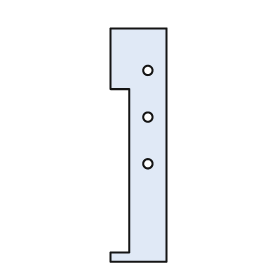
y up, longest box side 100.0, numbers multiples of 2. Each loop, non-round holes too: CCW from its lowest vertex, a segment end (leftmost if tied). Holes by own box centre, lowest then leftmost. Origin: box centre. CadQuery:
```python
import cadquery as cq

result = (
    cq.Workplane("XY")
    .moveTo(-12.0, -50.0)
    .lineTo(12.0, -50.0)
    .lineTo(12.0, 50.0)
    .lineTo(-12.0, 50.0)
    .lineTo(-12.0, 24.0)
    .lineTo(-4.0, 24.0)
    .lineTo(-4.0, -46.0)
    .lineTo(-12.0, -46.0)
    .close()
    .moveTo(4.0, -8.0)
    .circle(2.0)
    .moveTo(4.0, 12.0)
    .circle(2.0)
    .moveTo(4.0, 32.0)
    .circle(2.0)
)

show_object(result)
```